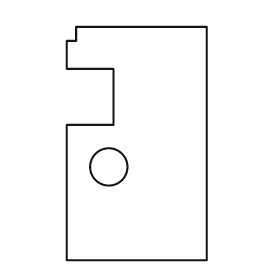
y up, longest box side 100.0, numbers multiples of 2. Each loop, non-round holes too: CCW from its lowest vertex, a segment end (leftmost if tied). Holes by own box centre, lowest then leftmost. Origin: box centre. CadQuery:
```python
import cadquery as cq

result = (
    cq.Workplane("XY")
    .moveTo(-30.0, -50.0)
    .lineTo(30.0, -50.0)
    .lineTo(30.0, 50.0)
    .lineTo(-26.0, 50.0)
    .lineTo(-26.0, 44.0)
    .lineTo(-30.0, 44.0)
    .lineTo(-30.0, 32.0)
    .lineTo(-10.0, 32.0)
    .lineTo(-10.0, 8.0)
    .lineTo(-30.0, 8.0)
    .close()
    .moveTo(-12.0, -10.0)
    .circle(8.0)
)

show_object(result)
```